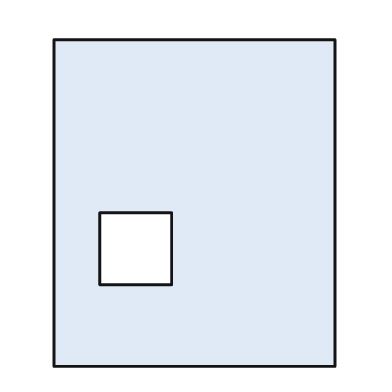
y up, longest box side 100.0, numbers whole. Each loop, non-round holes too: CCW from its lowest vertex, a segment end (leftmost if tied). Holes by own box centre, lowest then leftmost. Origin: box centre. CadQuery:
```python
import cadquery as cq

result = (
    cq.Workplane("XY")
    .moveTo(-43.0, -50.0)
    .lineTo(43.0, -50.0)
    .lineTo(43.0, 50.0)
    .lineTo(-43.0, 50.0)
    .close()
    .moveTo(-29.0, -25.0)
    .lineTo(-7.0, -25.0)
    .lineTo(-7.0, -3.0)
    .lineTo(-29.0, -3.0)
    .close()
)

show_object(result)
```